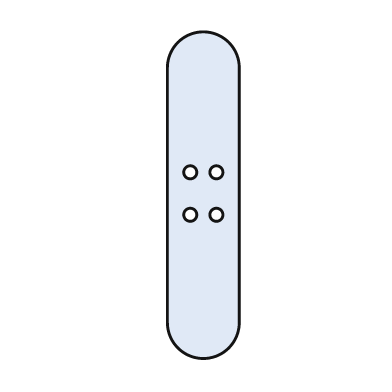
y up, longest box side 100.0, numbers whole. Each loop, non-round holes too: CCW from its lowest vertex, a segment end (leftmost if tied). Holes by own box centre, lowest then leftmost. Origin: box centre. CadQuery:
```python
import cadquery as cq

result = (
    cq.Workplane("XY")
    .moveTo(-11.0, -39.0)
    .threePointArc((0.0, -50.0), (11.0, -39.0))
    .lineTo(11.0, 39.0)
    .threePointArc((0.0, 50.0), (-11.0, 39.0))
    .close()
    .moveTo(-4.0, -6.0)
    .circle(2.0)
    .moveTo(4.0, -6.0)
    .circle(2.0)
    .moveTo(-4.0, 7.0)
    .circle(2.0)
    .moveTo(4.0, 7.0)
    .circle(2.0)
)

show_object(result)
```